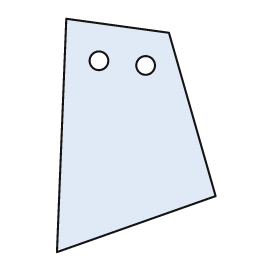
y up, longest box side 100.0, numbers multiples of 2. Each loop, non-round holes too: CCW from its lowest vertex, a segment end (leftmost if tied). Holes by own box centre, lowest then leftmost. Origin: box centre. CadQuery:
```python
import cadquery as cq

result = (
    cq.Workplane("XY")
    .moveTo(-34.0, -50.0)
    .lineTo(34.0, -26.0)
    .lineTo(14.0, 44.0)
    .lineTo(-30.0, 50.0)
    .close()
    .moveTo(4.0, 30.0)
    .circle(4.0)
    .moveTo(-16.0, 32.0)
    .circle(4.0)
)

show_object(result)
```